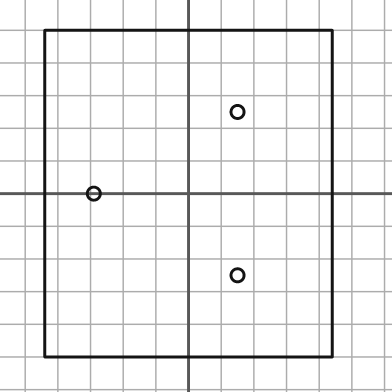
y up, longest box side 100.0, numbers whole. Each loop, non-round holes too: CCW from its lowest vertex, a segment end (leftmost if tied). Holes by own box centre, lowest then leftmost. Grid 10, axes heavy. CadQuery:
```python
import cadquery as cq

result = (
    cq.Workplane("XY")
    .moveTo(-44.0, -50.0)
    .lineTo(44.0, -50.0)
    .lineTo(44.0, 50.0)
    .lineTo(-44.0, 50.0)
    .close()
    .moveTo(15.0, -25.0)
    .circle(2.0)
    .moveTo(-29.0, 0.0)
    .circle(2.0)
    .moveTo(15.0, 25.0)
    .circle(2.0)
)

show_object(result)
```